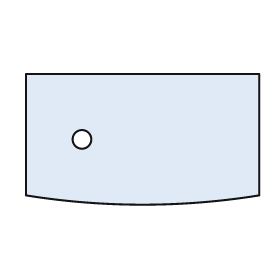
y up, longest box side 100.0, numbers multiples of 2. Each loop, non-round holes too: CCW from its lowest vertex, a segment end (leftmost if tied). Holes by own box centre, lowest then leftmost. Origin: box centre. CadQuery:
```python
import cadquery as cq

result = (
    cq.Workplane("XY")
    .moveTo(-50.0, -24.0)
    .threePointArc((0.0, -28.0), (50.0, -24.0))
    .lineTo(50.0, 28.0)
    .lineTo(-50.0, 28.0)
    .close()
    .moveTo(-26.0, 0.0)
    .circle(4.0)
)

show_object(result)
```